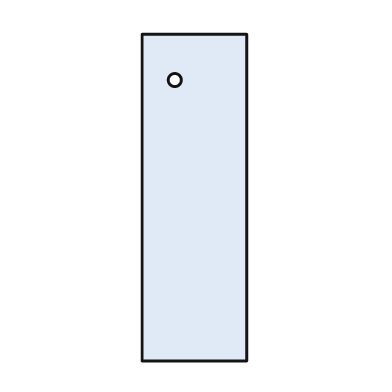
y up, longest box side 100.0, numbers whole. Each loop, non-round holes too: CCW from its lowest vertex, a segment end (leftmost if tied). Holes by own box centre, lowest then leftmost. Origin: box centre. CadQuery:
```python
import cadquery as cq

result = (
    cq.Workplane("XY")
    .moveTo(-16.0, -50.0)
    .lineTo(16.0, -50.0)
    .lineTo(16.0, 50.0)
    .lineTo(-16.0, 50.0)
    .close()
    .moveTo(-6.0, 36.0)
    .circle(2.0)
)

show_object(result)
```